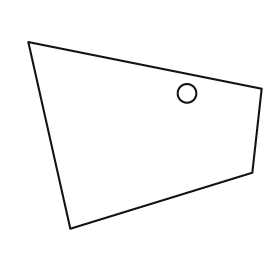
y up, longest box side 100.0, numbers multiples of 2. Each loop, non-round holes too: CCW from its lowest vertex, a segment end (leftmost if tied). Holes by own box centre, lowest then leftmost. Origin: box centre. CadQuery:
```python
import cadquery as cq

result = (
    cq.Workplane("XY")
    .moveTo(-32.0, -40.0)
    .lineTo(46.0, -16.0)
    .lineTo(50.0, 20.0)
    .lineTo(-50.0, 40.0)
    .close()
    .moveTo(18.0, 18.0)
    .circle(4.0)
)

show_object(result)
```